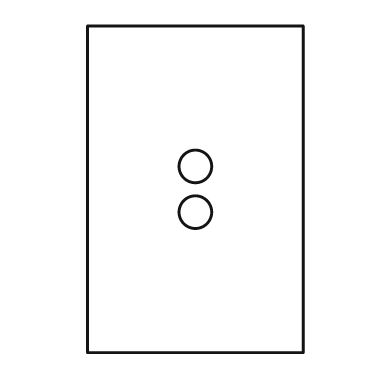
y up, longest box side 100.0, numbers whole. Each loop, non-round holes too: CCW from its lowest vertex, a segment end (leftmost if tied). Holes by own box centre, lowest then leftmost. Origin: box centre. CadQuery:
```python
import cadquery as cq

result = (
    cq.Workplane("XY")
    .moveTo(-33.0, -50.0)
    .lineTo(33.0, -50.0)
    .lineTo(33.0, 50.0)
    .lineTo(-33.0, 50.0)
    .close()
    .moveTo(0.0, -7.0)
    .circle(5.0)
    .moveTo(0.0, 7.0)
    .circle(5.0)
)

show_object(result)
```